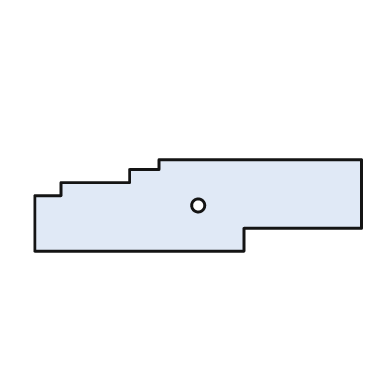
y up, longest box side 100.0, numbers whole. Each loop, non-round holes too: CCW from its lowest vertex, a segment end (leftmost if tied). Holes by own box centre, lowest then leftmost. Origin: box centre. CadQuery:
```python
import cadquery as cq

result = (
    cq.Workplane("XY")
    .moveTo(-50.0, -14.0)
    .lineTo(14.0, -14.0)
    .lineTo(14.0, -7.0)
    .lineTo(50.0, -7.0)
    .lineTo(50.0, 14.0)
    .lineTo(-12.0, 14.0)
    .lineTo(-12.0, 11.0)
    .lineTo(-21.0, 11.0)
    .lineTo(-21.0, 7.0)
    .lineTo(-42.0, 7.0)
    .lineTo(-42.0, 3.0)
    .lineTo(-50.0, 3.0)
    .close()
    .moveTo(0.0, 0.0)
    .circle(2.0)
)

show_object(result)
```